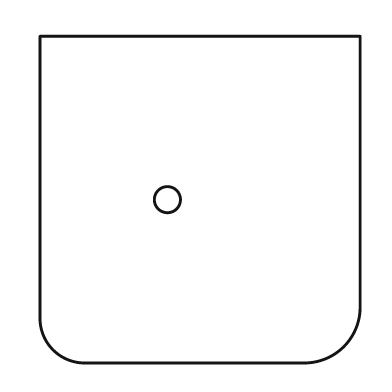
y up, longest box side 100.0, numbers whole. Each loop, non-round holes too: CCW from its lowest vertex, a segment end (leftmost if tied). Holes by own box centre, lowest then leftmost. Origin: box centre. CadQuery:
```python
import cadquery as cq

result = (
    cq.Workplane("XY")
    .moveTo(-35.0, -50.0)
    .lineTo(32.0, -50.0)
    .threePointArc((44.0, -45.0), (49.0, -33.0))
    .lineTo(49.0, 50.0)
    .lineTo(-49.0, 50.0)
    .lineTo(-49.0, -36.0)
    .threePointArc((-45.0, -46.0), (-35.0, -50.0))
    .close()
    .moveTo(-10.0, 0.0)
    .circle(4.0)
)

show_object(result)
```